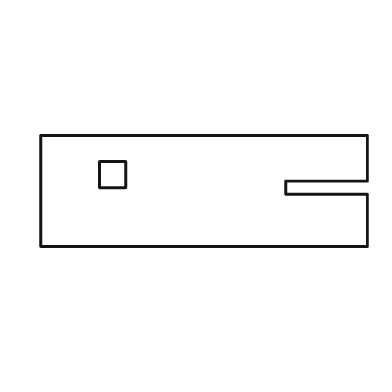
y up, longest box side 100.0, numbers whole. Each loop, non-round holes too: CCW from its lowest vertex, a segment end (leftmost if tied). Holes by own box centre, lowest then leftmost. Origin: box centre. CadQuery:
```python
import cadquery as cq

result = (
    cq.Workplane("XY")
    .moveTo(-50.0, -17.0)
    .lineTo(50.0, -17.0)
    .lineTo(50.0, -1.0)
    .lineTo(25.0, -1.0)
    .lineTo(25.0, 3.0)
    .lineTo(50.0, 3.0)
    .lineTo(50.0, 17.0)
    .lineTo(-50.0, 17.0)
    .close()
    .moveTo(-32.0, 1.0)
    .lineTo(-24.0, 1.0)
    .lineTo(-24.0, 9.0)
    .lineTo(-32.0, 9.0)
    .close()
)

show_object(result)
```